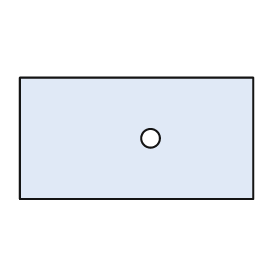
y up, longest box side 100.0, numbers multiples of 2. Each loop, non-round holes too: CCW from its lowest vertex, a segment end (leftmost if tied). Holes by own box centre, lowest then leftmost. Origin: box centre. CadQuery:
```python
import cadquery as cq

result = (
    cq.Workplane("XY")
    .moveTo(-50.0, -26.0)
    .lineTo(50.0, -26.0)
    .lineTo(50.0, 26.0)
    .lineTo(-50.0, 26.0)
    .close()
    .moveTo(6.0, 0.0)
    .circle(4.0)
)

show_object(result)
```